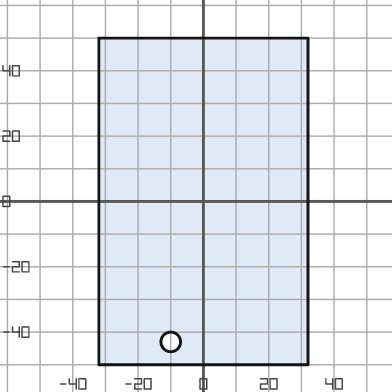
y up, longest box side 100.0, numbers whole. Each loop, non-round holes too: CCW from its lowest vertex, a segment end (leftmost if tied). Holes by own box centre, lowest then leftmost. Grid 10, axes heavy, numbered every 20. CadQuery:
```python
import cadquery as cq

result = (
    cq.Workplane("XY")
    .moveTo(-32.0, -50.0)
    .lineTo(32.0, -50.0)
    .lineTo(32.0, 50.0)
    .lineTo(-32.0, 50.0)
    .close()
    .moveTo(-10.0, -43.0)
    .circle(3.0)
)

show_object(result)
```